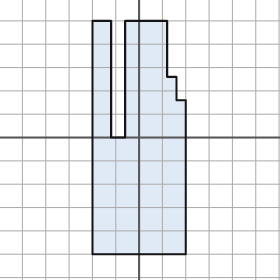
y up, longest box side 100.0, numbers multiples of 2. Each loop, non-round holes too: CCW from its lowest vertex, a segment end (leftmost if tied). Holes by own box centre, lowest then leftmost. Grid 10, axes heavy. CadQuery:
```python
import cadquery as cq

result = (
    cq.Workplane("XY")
    .moveTo(-20.0, -50.0)
    .lineTo(20.0, -50.0)
    .lineTo(20.0, 16.0)
    .lineTo(16.0, 16.0)
    .lineTo(16.0, 26.0)
    .lineTo(12.0, 26.0)
    .lineTo(12.0, 50.0)
    .lineTo(-6.0, 50.0)
    .lineTo(-6.0, 0.0)
    .lineTo(-12.0, 0.0)
    .lineTo(-12.0, 50.0)
    .lineTo(-20.0, 50.0)
    .close()
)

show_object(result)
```